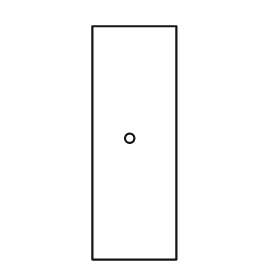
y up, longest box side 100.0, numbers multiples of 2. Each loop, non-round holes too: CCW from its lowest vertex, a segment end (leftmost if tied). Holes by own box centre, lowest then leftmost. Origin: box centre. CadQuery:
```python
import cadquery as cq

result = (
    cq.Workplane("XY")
    .moveTo(-18.0, -50.0)
    .lineTo(18.0, -50.0)
    .lineTo(18.0, 50.0)
    .lineTo(-18.0, 50.0)
    .close()
    .moveTo(-2.0, 2.0)
    .circle(2.0)
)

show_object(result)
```